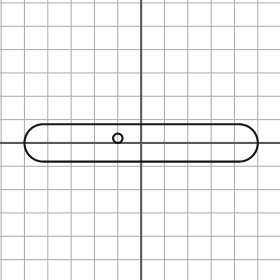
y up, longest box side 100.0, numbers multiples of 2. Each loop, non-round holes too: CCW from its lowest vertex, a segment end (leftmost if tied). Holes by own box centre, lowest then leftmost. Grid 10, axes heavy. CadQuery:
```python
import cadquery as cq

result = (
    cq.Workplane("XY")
    .moveTo(-42.0, -8.0)
    .lineTo(42.0, -8.0)
    .threePointArc((50.0, 0.0), (42.0, 8.0))
    .lineTo(-42.0, 8.0)
    .threePointArc((-50.0, 0.0), (-42.0, -8.0))
    .close()
    .moveTo(-10.0, 2.0)
    .circle(2.0)
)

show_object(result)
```